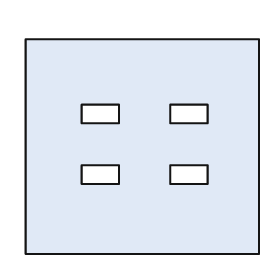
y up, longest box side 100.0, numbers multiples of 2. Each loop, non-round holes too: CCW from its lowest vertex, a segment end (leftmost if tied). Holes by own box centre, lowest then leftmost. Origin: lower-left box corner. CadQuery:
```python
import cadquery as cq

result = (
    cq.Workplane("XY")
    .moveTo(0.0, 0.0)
    .lineTo(100.0, 0.0)
    .lineTo(100.0, 92.0)
    .lineTo(0.0, 92.0)
    .close()
    .moveTo(24.0, 30.0)
    .lineTo(40.0, 30.0)
    .lineTo(40.0, 38.0)
    .lineTo(24.0, 38.0)
    .close()
    .moveTo(62.0, 30.0)
    .lineTo(78.0, 30.0)
    .lineTo(78.0, 38.0)
    .lineTo(62.0, 38.0)
    .close()
    .moveTo(24.0, 56.0)
    .lineTo(40.0, 56.0)
    .lineTo(40.0, 64.0)
    .lineTo(24.0, 64.0)
    .close()
    .moveTo(62.0, 56.0)
    .lineTo(78.0, 56.0)
    .lineTo(78.0, 64.0)
    .lineTo(62.0, 64.0)
    .close()
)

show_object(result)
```